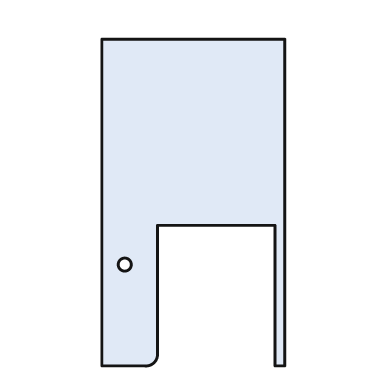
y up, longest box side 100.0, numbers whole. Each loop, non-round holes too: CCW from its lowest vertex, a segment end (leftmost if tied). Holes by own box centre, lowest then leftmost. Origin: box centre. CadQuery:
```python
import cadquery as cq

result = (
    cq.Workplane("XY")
    .moveTo(-28.0, -50.0)
    .lineTo(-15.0, -50.0)
    .threePointArc((-12.0, -49.0), (-11.0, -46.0))
    .lineTo(-11.0, -7.0)
    .lineTo(25.0, -7.0)
    .lineTo(25.0, -50.0)
    .lineTo(28.0, -50.0)
    .lineTo(28.0, 50.0)
    .lineTo(-28.0, 50.0)
    .close()
    .moveTo(-21.0, -19.0)
    .circle(2.0)
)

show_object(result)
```